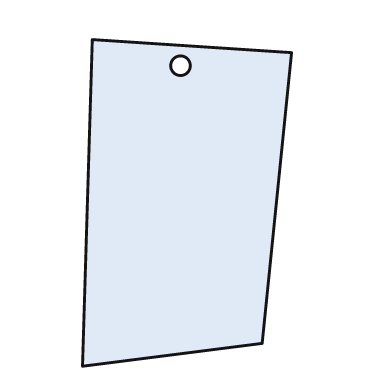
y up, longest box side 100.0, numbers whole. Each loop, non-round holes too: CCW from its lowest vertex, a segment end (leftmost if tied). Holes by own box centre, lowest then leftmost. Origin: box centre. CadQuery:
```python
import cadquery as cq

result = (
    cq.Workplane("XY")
    .moveTo(-32.0, -50.0)
    .lineTo(23.0, -43.0)
    .lineTo(32.0, 46.0)
    .lineTo(-29.0, 50.0)
    .close()
    .moveTo(-2.0, 42.0)
    .circle(3.0)
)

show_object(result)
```